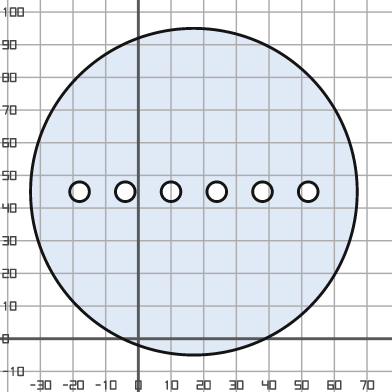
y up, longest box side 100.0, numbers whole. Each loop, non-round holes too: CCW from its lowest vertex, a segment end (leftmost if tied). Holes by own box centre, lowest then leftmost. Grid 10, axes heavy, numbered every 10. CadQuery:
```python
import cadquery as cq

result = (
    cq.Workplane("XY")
    .moveTo(17.0, 45.0)
    .circle(50.0)
    .moveTo(-18.0, 45.0)
    .circle(3.0)
    .moveTo(-4.0, 45.0)
    .circle(3.0)
    .moveTo(10.0, 45.0)
    .circle(3.0)
    .moveTo(24.0, 45.0)
    .circle(3.0)
    .moveTo(38.0, 45.0)
    .circle(3.0)
    .moveTo(52.0, 45.0)
    .circle(3.0)
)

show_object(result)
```